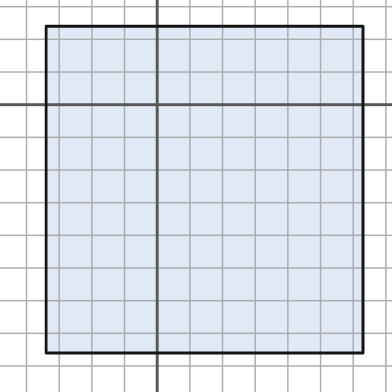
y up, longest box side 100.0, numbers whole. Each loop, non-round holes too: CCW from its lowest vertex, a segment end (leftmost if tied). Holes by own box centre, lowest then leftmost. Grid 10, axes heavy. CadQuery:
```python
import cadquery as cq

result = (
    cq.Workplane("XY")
    .moveTo(-34.0, -76.0)
    .lineTo(63.0, -76.0)
    .lineTo(63.0, 24.0)
    .lineTo(-34.0, 24.0)
    .close()
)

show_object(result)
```